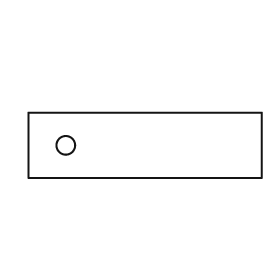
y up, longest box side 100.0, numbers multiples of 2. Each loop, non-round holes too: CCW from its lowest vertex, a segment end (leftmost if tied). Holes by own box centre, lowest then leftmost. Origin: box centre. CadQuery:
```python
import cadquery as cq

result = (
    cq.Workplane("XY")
    .moveTo(-50.0, -14.0)
    .lineTo(50.0, -14.0)
    .lineTo(50.0, 14.0)
    .lineTo(-50.0, 14.0)
    .close()
    .moveTo(-34.0, 0.0)
    .circle(4.0)
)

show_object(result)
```